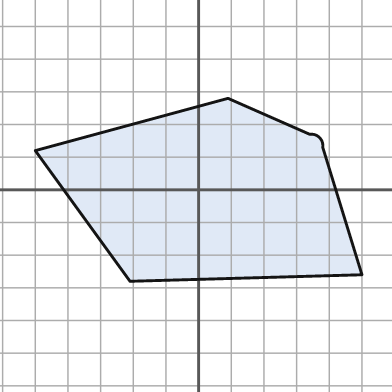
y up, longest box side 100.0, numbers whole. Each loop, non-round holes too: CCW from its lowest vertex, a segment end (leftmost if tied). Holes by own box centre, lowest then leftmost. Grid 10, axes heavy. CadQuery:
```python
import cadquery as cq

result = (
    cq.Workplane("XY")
    .moveTo(-21.0, -28.0)
    .lineTo(50.0, -26.0)
    .lineTo(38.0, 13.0)
    .threePointArc((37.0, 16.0), (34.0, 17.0))
    .lineTo(9.0, 28.0)
    .lineTo(-50.0, 12.0)
    .close()
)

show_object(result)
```